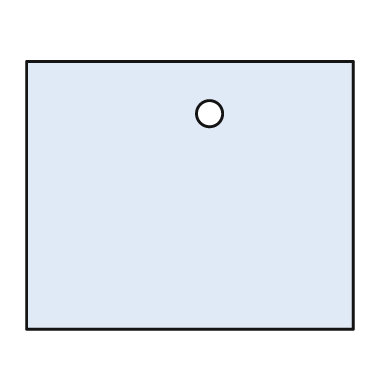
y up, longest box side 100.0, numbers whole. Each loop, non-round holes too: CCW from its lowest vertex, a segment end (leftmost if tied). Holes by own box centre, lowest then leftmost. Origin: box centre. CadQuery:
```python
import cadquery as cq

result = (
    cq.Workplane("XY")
    .moveTo(-50.0, -41.0)
    .lineTo(50.0, -41.0)
    .lineTo(50.0, 41.0)
    .lineTo(-50.0, 41.0)
    .close()
    .moveTo(6.0, 25.0)
    .circle(4.0)
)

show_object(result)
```